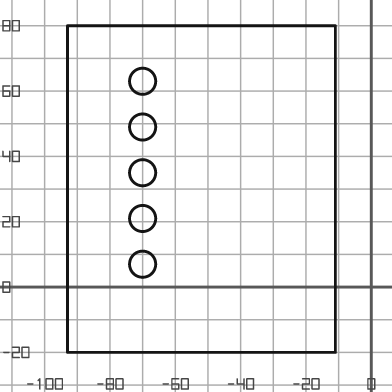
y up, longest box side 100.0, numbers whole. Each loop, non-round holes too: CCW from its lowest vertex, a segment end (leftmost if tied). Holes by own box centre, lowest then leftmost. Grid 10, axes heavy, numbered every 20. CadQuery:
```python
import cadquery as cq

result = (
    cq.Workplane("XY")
    .moveTo(-93.0, -20.0)
    .lineTo(-11.0, -20.0)
    .lineTo(-11.0, 80.0)
    .lineTo(-93.0, 80.0)
    .close()
    .moveTo(-70.0, 7.0)
    .circle(4.0)
    .moveTo(-70.0, 21.0)
    .circle(4.0)
    .moveTo(-70.0, 35.0)
    .circle(4.0)
    .moveTo(-70.0, 49.0)
    .circle(4.0)
    .moveTo(-70.0, 63.0)
    .circle(4.0)
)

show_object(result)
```